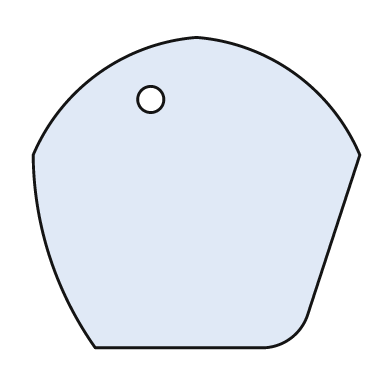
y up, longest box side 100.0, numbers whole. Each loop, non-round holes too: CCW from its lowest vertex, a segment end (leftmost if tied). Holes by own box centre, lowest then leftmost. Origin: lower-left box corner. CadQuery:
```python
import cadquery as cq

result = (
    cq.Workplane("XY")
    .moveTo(19.0, 0.0)
    .lineTo(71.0, 0.0)
    .threePointArc((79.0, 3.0), (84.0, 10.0))
    .lineTo(100.0, 59.0)
    .threePointArc((80.0, 84.0), (50.0, 95.0))
    .threePointArc((20.0, 84.0), (0.0, 59.0))
    .threePointArc((5.0, 28.0), (19.0, 0.0))
    .close()
    .moveTo(36.0, 76.0)
    .circle(4.0)
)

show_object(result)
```